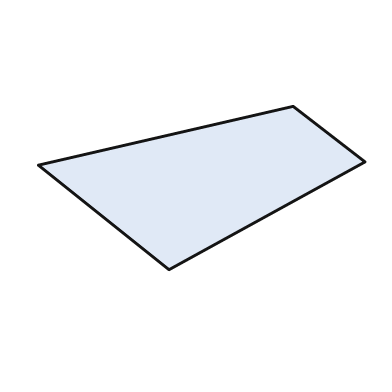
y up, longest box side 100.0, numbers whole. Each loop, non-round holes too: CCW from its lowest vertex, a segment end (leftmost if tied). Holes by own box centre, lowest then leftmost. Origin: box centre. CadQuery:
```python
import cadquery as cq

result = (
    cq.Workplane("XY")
    .moveTo(-10.0, -25.0)
    .lineTo(50.0, 8.0)
    .lineTo(28.0, 25.0)
    .lineTo(-50.0, 7.0)
    .close()
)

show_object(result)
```